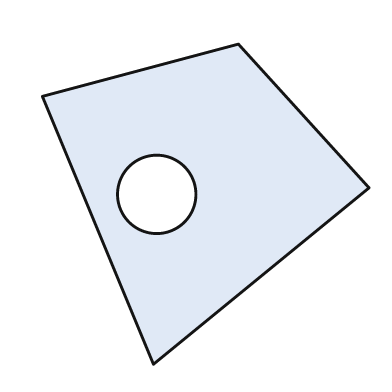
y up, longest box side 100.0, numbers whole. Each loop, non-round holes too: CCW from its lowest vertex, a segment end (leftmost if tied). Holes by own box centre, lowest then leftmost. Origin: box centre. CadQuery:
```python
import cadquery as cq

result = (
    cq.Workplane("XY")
    .moveTo(-16.0, -49.0)
    .lineTo(50.0, 5.0)
    .lineTo(10.0, 49.0)
    .lineTo(-50.0, 33.0)
    .close()
    .moveTo(-15.0, 3.0)
    .circle(12.0)
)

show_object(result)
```